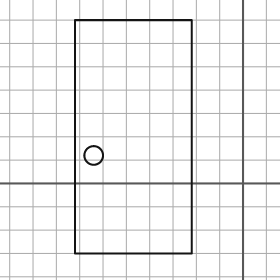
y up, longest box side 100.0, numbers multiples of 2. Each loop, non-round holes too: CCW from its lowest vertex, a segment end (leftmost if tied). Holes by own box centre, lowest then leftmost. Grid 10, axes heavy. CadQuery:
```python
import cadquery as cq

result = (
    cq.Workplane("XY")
    .moveTo(-72.0, -30.0)
    .lineTo(-22.0, -30.0)
    .lineTo(-22.0, 70.0)
    .lineTo(-72.0, 70.0)
    .close()
    .moveTo(-64.0, 12.0)
    .circle(4.0)
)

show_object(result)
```